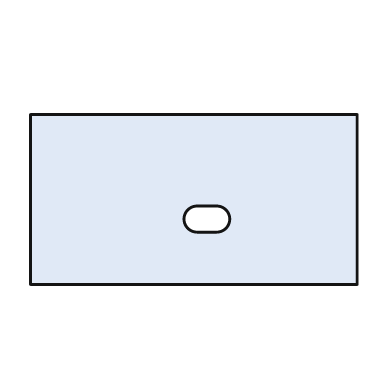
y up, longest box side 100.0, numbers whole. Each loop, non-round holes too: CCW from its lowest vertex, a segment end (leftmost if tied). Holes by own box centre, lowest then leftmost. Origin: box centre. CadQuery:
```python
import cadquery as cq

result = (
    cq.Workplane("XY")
    .moveTo(-50.0, -26.0)
    .lineTo(50.0, -26.0)
    .lineTo(50.0, 26.0)
    .lineTo(-50.0, 26.0)
    .close()
    .moveTo(1.0, -10.0)
    .lineTo(7.0, -10.0)
    .threePointArc((11.0, -6.0), (7.0, -2.0))
    .lineTo(1.0, -2.0)
    .threePointArc((-3.0, -6.0), (1.0, -10.0))
    .close()
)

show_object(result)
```